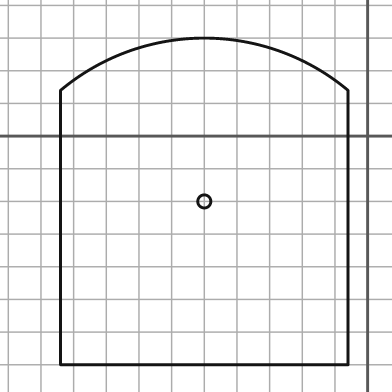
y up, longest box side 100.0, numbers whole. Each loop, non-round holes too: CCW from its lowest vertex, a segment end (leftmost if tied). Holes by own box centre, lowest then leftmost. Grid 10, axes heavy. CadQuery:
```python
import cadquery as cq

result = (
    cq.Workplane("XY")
    .moveTo(-94.0, -70.0)
    .lineTo(-6.0, -70.0)
    .lineTo(-6.0, 14.0)
    .threePointArc((-50.0, 30.0), (-94.0, 14.0))
    .close()
    .moveTo(-50.0, -20.0)
    .circle(2.0)
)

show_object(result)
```